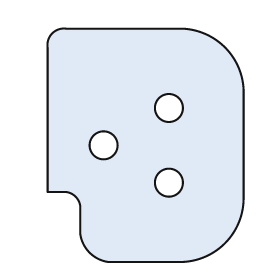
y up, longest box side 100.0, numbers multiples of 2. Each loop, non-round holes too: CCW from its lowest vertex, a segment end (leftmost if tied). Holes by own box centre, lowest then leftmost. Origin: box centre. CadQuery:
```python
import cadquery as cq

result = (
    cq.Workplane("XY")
    .moveTo(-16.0, -50.0)
    .lineTo(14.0, -50.0)
    .threePointArc((34.0, -42.0), (42.0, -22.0))
    .lineTo(42.0, 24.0)
    .threePointArc((34.0, 42.0), (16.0, 50.0))
    .lineTo(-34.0, 50.0)
    .threePointArc((-40.0, 48.0), (-42.0, 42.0))
    .lineTo(-42.0, -20.0)
    .lineTo(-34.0, -20.0)
    .threePointArc((-30.0, -22.0), (-28.0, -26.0))
    .lineTo(-28.0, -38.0)
    .threePointArc((-24.0, -46.0), (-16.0, -50.0))
    .close()
    .moveTo(10.0, -16.0)
    .circle(6.0)
    .moveTo(-18.0, 0.0)
    .circle(6.0)
    .moveTo(10.0, 16.0)
    .circle(6.0)
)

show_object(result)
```